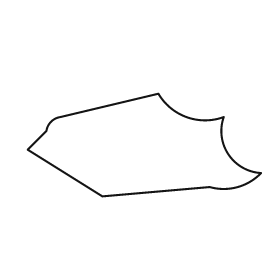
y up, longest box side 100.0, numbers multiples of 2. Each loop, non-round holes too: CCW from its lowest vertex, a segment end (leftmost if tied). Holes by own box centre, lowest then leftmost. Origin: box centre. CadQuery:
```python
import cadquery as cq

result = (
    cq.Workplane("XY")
    .moveTo(-18.0, -22.0)
    .lineTo(28.0, -18.0)
    .threePointArc((40.0, -18.0), (50.0, -12.0))
    .threePointArc((36.0, -4.0), (34.0, 12.0))
    .threePointArc((18.0, 12.0), (6.0, 22.0))
    .lineTo(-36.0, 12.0)
    .threePointArc((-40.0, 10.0), (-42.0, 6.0))
    .lineTo(-50.0, -2.0)
    .close()
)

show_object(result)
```